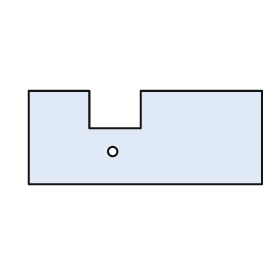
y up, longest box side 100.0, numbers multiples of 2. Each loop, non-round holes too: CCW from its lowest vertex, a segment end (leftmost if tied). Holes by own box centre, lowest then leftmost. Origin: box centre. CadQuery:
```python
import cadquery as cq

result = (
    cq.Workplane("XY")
    .moveTo(-50.0, -20.0)
    .lineTo(50.0, -20.0)
    .lineTo(50.0, 20.0)
    .lineTo(-2.0, 20.0)
    .lineTo(-2.0, 4.0)
    .lineTo(-24.0, 4.0)
    .lineTo(-24.0, 20.0)
    .lineTo(-50.0, 20.0)
    .close()
    .moveTo(-14.0, -6.0)
    .circle(2.0)
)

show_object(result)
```